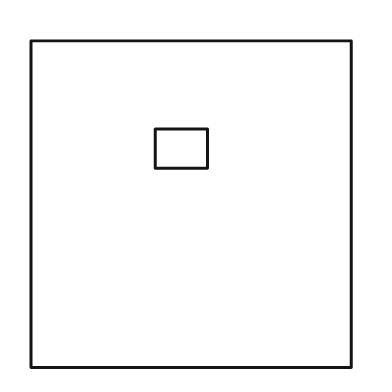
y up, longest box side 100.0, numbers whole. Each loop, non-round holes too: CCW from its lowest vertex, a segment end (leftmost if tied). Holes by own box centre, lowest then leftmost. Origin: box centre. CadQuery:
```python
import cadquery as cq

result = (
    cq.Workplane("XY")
    .moveTo(-49.0, -50.0)
    .lineTo(49.0, -50.0)
    .lineTo(49.0, 50.0)
    .lineTo(-49.0, 50.0)
    .close()
    .moveTo(-11.0, 11.0)
    .lineTo(5.0, 11.0)
    .lineTo(5.0, 23.0)
    .lineTo(-11.0, 23.0)
    .close()
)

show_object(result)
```